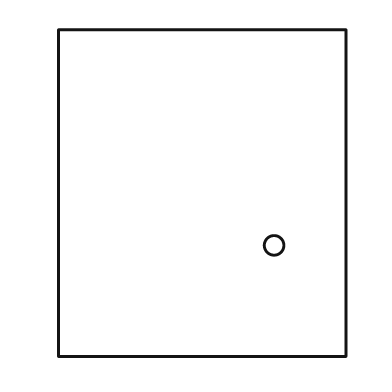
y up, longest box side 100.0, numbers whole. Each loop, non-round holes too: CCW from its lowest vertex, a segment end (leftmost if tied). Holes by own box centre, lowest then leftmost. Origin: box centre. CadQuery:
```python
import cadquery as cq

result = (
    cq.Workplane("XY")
    .moveTo(-44.0, -50.0)
    .lineTo(44.0, -50.0)
    .lineTo(44.0, 50.0)
    .lineTo(-44.0, 50.0)
    .close()
    .moveTo(22.0, -16.0)
    .circle(3.0)
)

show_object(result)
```